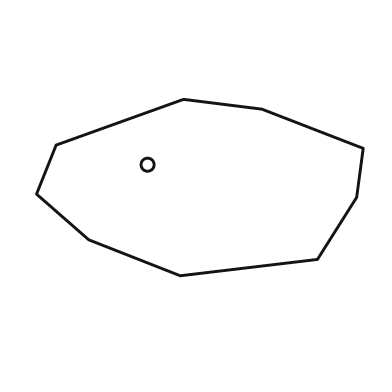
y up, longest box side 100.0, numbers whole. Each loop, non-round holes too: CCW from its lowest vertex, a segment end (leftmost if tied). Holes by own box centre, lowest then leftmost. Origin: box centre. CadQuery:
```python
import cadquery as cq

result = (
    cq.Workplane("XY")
    .moveTo(-6.0, -27.0)
    .lineTo(36.0, -22.0)
    .lineTo(48.0, -3.0)
    .lineTo(50.0, 12.0)
    .lineTo(19.0, 24.0)
    .lineTo(-5.0, 27.0)
    .lineTo(-44.0, 13.0)
    .lineTo(-50.0, -2.0)
    .lineTo(-34.0, -16.0)
    .close()
    .moveTo(-16.0, 7.0)
    .circle(2.0)
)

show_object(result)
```